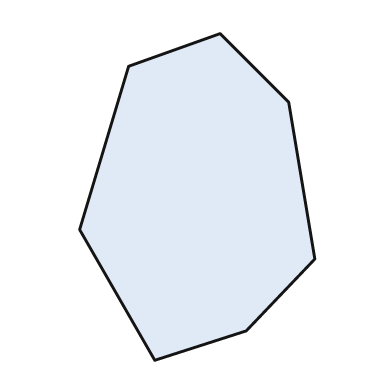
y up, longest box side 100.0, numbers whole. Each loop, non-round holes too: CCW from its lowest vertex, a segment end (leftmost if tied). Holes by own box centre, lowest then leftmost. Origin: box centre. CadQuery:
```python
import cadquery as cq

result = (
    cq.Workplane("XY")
    .moveTo(-13.0, -50.0)
    .lineTo(15.0, -41.0)
    .lineTo(36.0, -19.0)
    .lineTo(28.0, 29.0)
    .lineTo(7.0, 50.0)
    .lineTo(-21.0, 40.0)
    .lineTo(-36.0, -10.0)
    .close()
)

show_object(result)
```